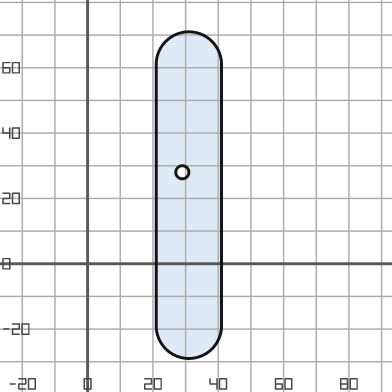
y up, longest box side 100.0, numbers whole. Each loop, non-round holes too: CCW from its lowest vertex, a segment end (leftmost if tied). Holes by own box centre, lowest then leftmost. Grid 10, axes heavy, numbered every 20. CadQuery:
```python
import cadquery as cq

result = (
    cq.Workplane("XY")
    .moveTo(21.0, -19.0)
    .threePointArc((31.0, -29.0), (41.0, -19.0))
    .lineTo(41.0, 61.0)
    .threePointArc((31.0, 71.0), (21.0, 61.0))
    .close()
    .moveTo(29.0, 28.0)
    .circle(2.0)
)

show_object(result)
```